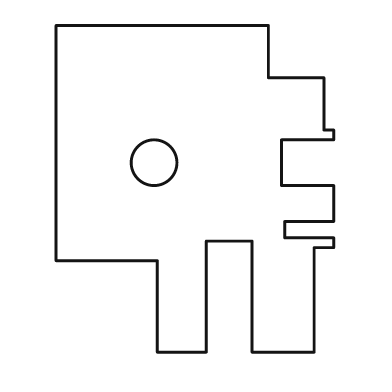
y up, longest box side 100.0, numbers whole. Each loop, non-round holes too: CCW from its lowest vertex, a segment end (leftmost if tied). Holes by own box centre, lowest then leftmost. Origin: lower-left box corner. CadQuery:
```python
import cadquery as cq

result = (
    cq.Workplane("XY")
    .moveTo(31.0, 0.0)
    .lineTo(46.0, 0.0)
    .lineTo(46.0, 34.0)
    .lineTo(60.0, 34.0)
    .lineTo(60.0, 0.0)
    .lineTo(79.0, 0.0)
    .lineTo(79.0, 32.0)
    .lineTo(85.0, 32.0)
    .lineTo(85.0, 35.0)
    .lineTo(70.0, 35.0)
    .lineTo(70.0, 40.0)
    .lineTo(85.0, 40.0)
    .lineTo(85.0, 51.0)
    .lineTo(69.0, 51.0)
    .lineTo(69.0, 65.0)
    .lineTo(85.0, 65.0)
    .lineTo(85.0, 68.0)
    .lineTo(82.0, 68.0)
    .lineTo(82.0, 84.0)
    .lineTo(65.0, 84.0)
    .lineTo(65.0, 100.0)
    .lineTo(0.0, 100.0)
    .lineTo(0.0, 28.0)
    .lineTo(31.0, 28.0)
    .close()
    .moveTo(30.0, 58.0)
    .circle(7.0)
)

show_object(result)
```